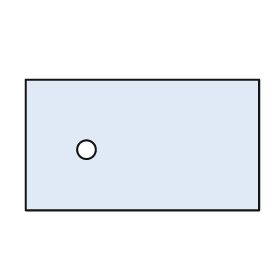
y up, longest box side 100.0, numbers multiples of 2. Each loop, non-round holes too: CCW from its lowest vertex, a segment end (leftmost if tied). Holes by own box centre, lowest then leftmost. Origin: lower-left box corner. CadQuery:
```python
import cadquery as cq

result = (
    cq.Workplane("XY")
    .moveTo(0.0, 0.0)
    .lineTo(100.0, 0.0)
    .lineTo(100.0, 56.0)
    .lineTo(0.0, 56.0)
    .close()
    .moveTo(26.0, 26.0)
    .circle(4.0)
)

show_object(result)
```